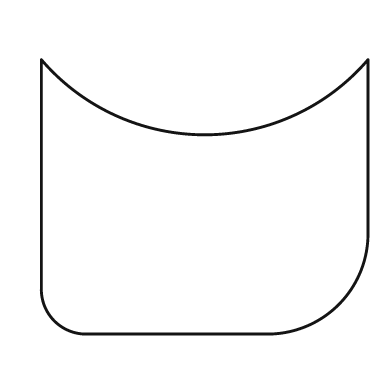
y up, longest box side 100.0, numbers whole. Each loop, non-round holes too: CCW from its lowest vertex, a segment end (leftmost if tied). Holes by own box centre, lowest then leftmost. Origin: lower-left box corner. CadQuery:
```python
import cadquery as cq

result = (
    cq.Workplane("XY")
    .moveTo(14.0, 0.0)
    .lineTo(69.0, 0.0)
    .threePointArc((91.0, 9.0), (100.0, 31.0))
    .lineTo(100.0, 84.0)
    .threePointArc((50.0, 61.0), (0.0, 84.0))
    .lineTo(0.0, 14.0)
    .threePointArc((4.0, 4.0), (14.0, 0.0))
    .close()
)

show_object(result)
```